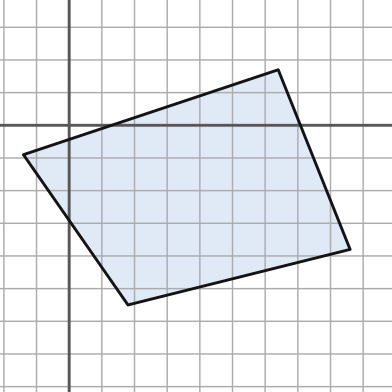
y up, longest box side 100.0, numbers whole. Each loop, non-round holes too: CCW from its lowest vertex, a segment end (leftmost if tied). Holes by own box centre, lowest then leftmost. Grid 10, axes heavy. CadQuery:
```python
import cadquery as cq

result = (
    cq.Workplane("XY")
    .moveTo(18.0, -55.0)
    .lineTo(86.0, -38.0)
    .lineTo(64.0, 17.0)
    .lineTo(-14.0, -9.0)
    .close()
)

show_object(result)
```